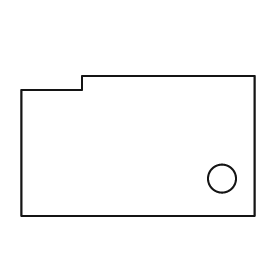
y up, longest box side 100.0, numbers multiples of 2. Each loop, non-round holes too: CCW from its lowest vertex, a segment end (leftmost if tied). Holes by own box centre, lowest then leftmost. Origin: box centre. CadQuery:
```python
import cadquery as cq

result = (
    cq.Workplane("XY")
    .moveTo(-50.0, -30.0)
    .lineTo(50.0, -30.0)
    .lineTo(50.0, 30.0)
    .lineTo(-24.0, 30.0)
    .lineTo(-24.0, 24.0)
    .lineTo(-50.0, 24.0)
    .close()
    .moveTo(36.0, -14.0)
    .circle(6.0)
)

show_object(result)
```